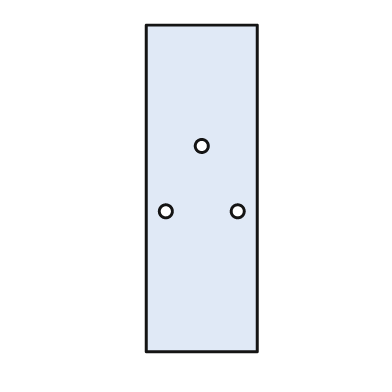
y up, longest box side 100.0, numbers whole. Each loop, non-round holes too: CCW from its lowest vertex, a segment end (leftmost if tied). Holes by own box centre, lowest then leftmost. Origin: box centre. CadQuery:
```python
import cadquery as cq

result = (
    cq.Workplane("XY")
    .moveTo(-17.0, -50.0)
    .lineTo(17.0, -50.0)
    .lineTo(17.0, 50.0)
    .lineTo(-17.0, 50.0)
    .close()
    .moveTo(-11.0, -7.0)
    .circle(2.0)
    .moveTo(11.0, -7.0)
    .circle(2.0)
    .moveTo(0.0, 13.0)
    .circle(2.0)
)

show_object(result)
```